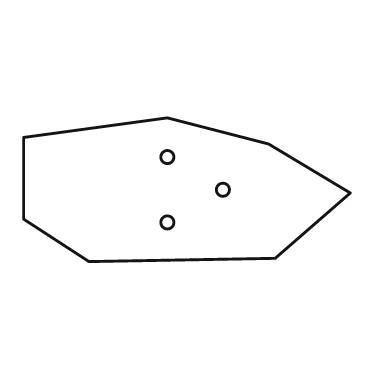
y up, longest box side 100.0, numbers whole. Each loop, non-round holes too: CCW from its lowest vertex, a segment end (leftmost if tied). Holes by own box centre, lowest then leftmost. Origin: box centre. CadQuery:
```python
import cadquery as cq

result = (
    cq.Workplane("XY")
    .moveTo(-30.0, -22.0)
    .lineTo(27.0, -21.0)
    .lineTo(50.0, -1.0)
    .lineTo(25.0, 14.0)
    .lineTo(-6.0, 22.0)
    .lineTo(-50.0, 16.0)
    .lineTo(-50.0, -9.0)
    .close()
    .moveTo(-6.0, -10.0)
    .circle(2.0)
    .moveTo(11.0, 0.0)
    .circle(2.0)
    .moveTo(-6.0, 10.0)
    .circle(2.0)
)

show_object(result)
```